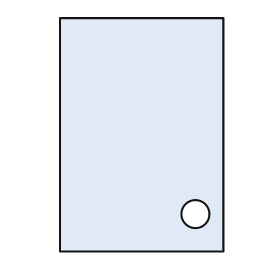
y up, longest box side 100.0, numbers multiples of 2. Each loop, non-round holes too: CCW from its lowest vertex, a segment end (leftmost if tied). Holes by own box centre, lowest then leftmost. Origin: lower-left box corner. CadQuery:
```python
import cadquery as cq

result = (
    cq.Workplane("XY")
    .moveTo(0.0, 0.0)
    .lineTo(70.0, 0.0)
    .lineTo(70.0, 100.0)
    .lineTo(0.0, 100.0)
    .close()
    .moveTo(58.0, 16.0)
    .circle(6.0)
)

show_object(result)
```